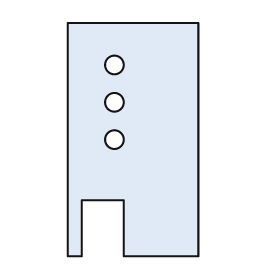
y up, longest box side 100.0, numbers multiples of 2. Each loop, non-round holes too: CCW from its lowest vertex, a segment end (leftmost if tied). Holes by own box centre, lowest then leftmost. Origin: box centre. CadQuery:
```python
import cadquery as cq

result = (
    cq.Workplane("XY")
    .moveTo(-28.0, -50.0)
    .lineTo(-22.0, -50.0)
    .lineTo(-22.0, -26.0)
    .lineTo(-4.0, -26.0)
    .lineTo(-4.0, -50.0)
    .lineTo(28.0, -50.0)
    .lineTo(28.0, 50.0)
    .lineTo(-28.0, 50.0)
    .close()
    .moveTo(-8.0, 0.0)
    .circle(4.0)
    .moveTo(-8.0, 16.0)
    .circle(4.0)
    .moveTo(-8.0, 32.0)
    .circle(4.0)
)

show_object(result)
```